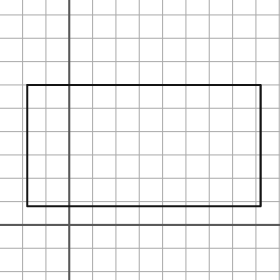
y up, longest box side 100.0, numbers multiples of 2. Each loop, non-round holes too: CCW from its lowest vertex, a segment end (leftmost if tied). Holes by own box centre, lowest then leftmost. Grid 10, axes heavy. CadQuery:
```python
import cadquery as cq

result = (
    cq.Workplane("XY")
    .moveTo(-18.0, 8.0)
    .lineTo(82.0, 8.0)
    .lineTo(82.0, 60.0)
    .lineTo(-18.0, 60.0)
    .close()
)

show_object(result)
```